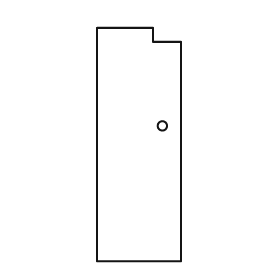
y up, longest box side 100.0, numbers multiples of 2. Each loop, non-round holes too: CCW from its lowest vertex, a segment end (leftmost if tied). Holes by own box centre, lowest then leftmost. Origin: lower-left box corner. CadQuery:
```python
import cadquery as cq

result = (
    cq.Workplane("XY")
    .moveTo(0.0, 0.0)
    .lineTo(36.0, 0.0)
    .lineTo(36.0, 94.0)
    .lineTo(24.0, 94.0)
    .lineTo(24.0, 100.0)
    .lineTo(0.0, 100.0)
    .close()
    .moveTo(28.0, 58.0)
    .circle(2.0)
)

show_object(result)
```